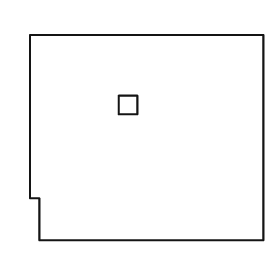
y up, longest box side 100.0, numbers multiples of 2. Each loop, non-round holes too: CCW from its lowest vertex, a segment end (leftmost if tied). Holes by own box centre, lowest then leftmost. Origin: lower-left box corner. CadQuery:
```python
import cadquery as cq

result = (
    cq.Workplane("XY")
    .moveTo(4.0, 0.0)
    .lineTo(100.0, 0.0)
    .lineTo(100.0, 88.0)
    .lineTo(0.0, 88.0)
    .lineTo(0.0, 18.0)
    .lineTo(4.0, 18.0)
    .close()
    .moveTo(38.0, 54.0)
    .lineTo(46.0, 54.0)
    .lineTo(46.0, 62.0)
    .lineTo(38.0, 62.0)
    .close()
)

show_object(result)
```